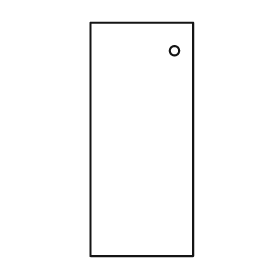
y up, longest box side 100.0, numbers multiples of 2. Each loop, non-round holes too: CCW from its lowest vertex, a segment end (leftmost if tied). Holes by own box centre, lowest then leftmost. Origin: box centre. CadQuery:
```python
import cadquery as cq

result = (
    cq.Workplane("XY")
    .moveTo(-22.0, -50.0)
    .lineTo(22.0, -50.0)
    .lineTo(22.0, 50.0)
    .lineTo(-22.0, 50.0)
    .close()
    .moveTo(14.0, 38.0)
    .circle(2.0)
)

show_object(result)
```